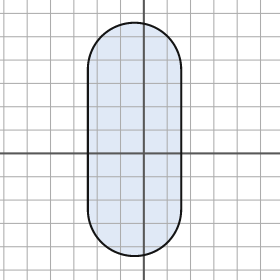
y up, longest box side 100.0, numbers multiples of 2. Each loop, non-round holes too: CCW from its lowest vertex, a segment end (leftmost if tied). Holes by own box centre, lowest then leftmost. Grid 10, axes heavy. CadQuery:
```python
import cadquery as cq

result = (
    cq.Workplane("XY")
    .moveTo(-24.0, -24.0)
    .threePointArc((-4.0, -44.0), (16.0, -24.0))
    .lineTo(16.0, 36.0)
    .threePointArc((-4.0, 56.0), (-24.0, 36.0))
    .close()
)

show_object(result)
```